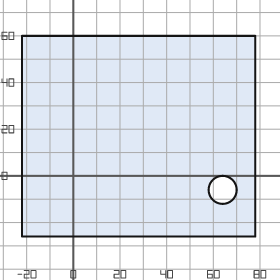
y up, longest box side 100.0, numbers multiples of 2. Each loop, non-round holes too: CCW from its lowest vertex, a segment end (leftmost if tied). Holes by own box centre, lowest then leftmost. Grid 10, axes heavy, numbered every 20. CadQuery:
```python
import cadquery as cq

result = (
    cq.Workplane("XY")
    .moveTo(-22.0, -26.0)
    .lineTo(78.0, -26.0)
    .lineTo(78.0, 60.0)
    .lineTo(-22.0, 60.0)
    .close()
    .moveTo(64.0, -6.0)
    .circle(6.0)
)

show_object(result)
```